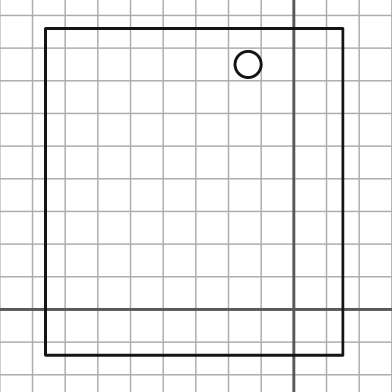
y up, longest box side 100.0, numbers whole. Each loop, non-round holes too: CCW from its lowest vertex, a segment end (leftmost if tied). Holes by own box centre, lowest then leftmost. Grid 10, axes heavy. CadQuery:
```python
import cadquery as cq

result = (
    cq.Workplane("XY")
    .moveTo(-76.0, -14.0)
    .lineTo(15.0, -14.0)
    .lineTo(15.0, 86.0)
    .lineTo(-76.0, 86.0)
    .close()
    .moveTo(-14.0, 75.0)
    .circle(4.0)
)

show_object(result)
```